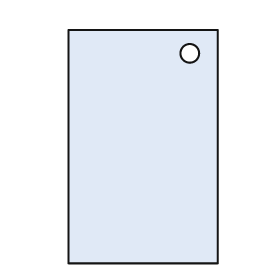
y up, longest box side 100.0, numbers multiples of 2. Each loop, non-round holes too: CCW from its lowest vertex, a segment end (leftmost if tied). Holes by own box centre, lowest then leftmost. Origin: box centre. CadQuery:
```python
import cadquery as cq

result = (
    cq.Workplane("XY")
    .moveTo(-32.0, -50.0)
    .lineTo(32.0, -50.0)
    .lineTo(32.0, 50.0)
    .lineTo(-32.0, 50.0)
    .close()
    .moveTo(20.0, 40.0)
    .circle(4.0)
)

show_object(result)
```